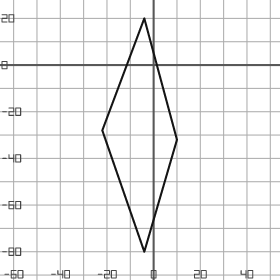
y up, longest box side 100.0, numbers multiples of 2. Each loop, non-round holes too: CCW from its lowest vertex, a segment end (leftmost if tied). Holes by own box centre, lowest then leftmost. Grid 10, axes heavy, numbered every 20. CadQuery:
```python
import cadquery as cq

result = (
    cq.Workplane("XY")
    .moveTo(-4.0, -80.0)
    .lineTo(10.0, -32.0)
    .lineTo(-4.0, 20.0)
    .lineTo(-22.0, -28.0)
    .close()
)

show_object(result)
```